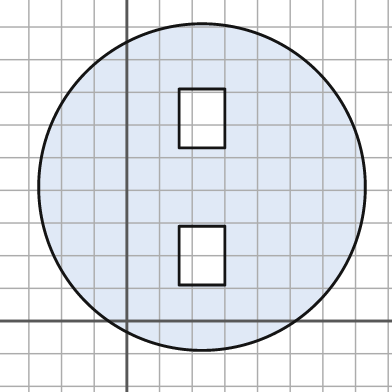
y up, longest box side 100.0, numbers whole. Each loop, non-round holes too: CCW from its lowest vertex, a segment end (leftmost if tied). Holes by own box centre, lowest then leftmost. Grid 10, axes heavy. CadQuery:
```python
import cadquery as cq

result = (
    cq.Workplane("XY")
    .moveTo(23.0, 41.0)
    .circle(50.0)
    .moveTo(16.0, 11.0)
    .lineTo(30.0, 11.0)
    .lineTo(30.0, 29.0)
    .lineTo(16.0, 29.0)
    .close()
    .moveTo(16.0, 53.0)
    .lineTo(30.0, 53.0)
    .lineTo(30.0, 71.0)
    .lineTo(16.0, 71.0)
    .close()
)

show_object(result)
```